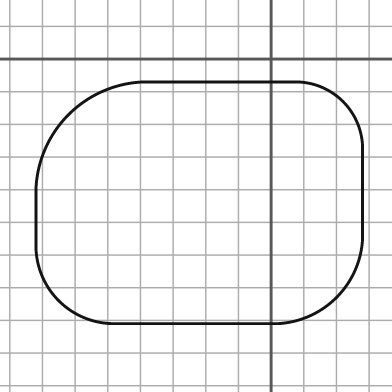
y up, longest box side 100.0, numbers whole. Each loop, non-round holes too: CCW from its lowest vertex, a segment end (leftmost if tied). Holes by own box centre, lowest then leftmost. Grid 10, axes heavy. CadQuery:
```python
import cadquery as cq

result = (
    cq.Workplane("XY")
    .moveTo(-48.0, -81.0)
    .lineTo(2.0, -81.0)
    .threePointArc((20.0, -73.0), (28.0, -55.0))
    .lineTo(28.0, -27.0)
    .threePointArc((22.0, -13.0), (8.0, -7.0))
    .lineTo(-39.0, -7.0)
    .threePointArc((-62.0, -17.0), (-72.0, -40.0))
    .lineTo(-72.0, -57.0)
    .threePointArc((-65.0, -74.0), (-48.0, -81.0))
    .close()
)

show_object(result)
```